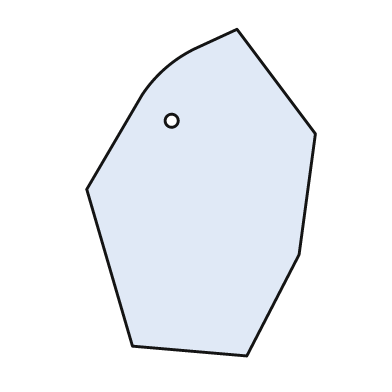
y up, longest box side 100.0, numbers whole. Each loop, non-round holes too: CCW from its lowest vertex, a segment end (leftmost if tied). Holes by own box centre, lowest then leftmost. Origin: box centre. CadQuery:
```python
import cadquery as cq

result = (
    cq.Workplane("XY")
    .moveTo(14.0, -50.0)
    .lineTo(30.0, -19.0)
    .lineTo(35.0, 18.0)
    .lineTo(11.0, 50.0)
    .lineTo(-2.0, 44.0)
    .threePointArc((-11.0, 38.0), (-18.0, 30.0))
    .lineTo(-35.0, 1.0)
    .lineTo(-21.0, -47.0)
    .close()
    .moveTo(-9.0, 22.0)
    .circle(2.0)
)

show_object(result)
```